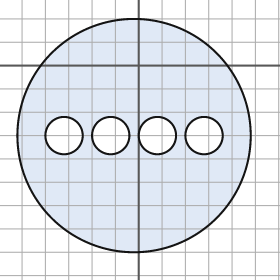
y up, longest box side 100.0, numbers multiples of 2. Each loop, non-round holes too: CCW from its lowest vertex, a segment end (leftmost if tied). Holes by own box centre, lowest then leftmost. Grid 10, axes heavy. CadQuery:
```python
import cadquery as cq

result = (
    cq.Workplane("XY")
    .moveTo(-2.0, -30.0)
    .circle(50.0)
    .moveTo(-32.0, -30.0)
    .circle(8.0)
    .moveTo(-12.0, -30.0)
    .circle(8.0)
    .moveTo(8.0, -30.0)
    .circle(8.0)
    .moveTo(28.0, -30.0)
    .circle(8.0)
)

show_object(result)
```